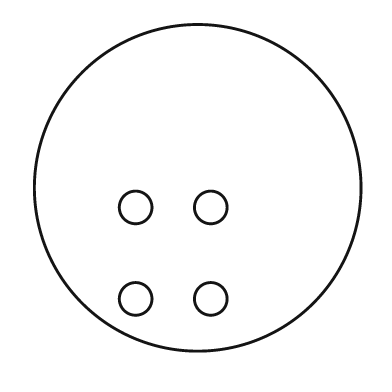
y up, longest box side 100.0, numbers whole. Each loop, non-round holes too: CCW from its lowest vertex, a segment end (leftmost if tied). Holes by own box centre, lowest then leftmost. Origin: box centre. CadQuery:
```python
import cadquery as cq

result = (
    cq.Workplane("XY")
    .moveTo(0.0, 0.0)
    .circle(50.0)
    .moveTo(-19.0, -34.0)
    .circle(5.0)
    .moveTo(4.0, -34.0)
    .circle(5.0)
    .moveTo(-19.0, -6.0)
    .circle(5.0)
    .moveTo(4.0, -6.0)
    .circle(5.0)
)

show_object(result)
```